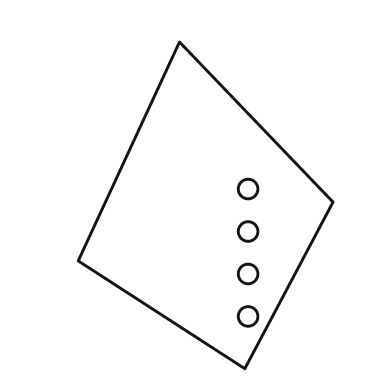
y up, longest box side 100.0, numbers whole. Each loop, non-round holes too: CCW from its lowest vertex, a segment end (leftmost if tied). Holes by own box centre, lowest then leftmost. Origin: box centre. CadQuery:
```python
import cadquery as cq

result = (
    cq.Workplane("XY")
    .moveTo(12.0, -50.0)
    .lineTo(39.0, 1.0)
    .lineTo(-8.0, 50.0)
    .lineTo(-39.0, -17.0)
    .close()
    .moveTo(13.0, -34.0)
    .circle(3.0)
    .moveTo(13.0, -21.0)
    .circle(3.0)
    .moveTo(13.0, -8.0)
    .circle(3.0)
    .moveTo(13.0, 5.0)
    .circle(3.0)
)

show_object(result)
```